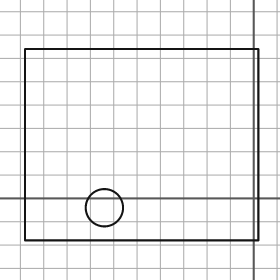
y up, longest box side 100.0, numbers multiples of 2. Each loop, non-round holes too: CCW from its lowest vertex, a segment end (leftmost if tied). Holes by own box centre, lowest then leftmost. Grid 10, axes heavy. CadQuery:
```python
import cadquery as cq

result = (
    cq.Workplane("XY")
    .moveTo(-98.0, -18.0)
    .lineTo(2.0, -18.0)
    .lineTo(2.0, 64.0)
    .lineTo(-98.0, 64.0)
    .close()
    .moveTo(-64.0, -4.0)
    .circle(8.0)
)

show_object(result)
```